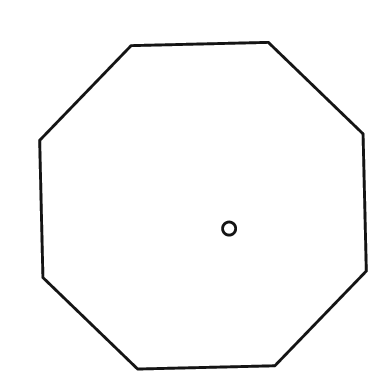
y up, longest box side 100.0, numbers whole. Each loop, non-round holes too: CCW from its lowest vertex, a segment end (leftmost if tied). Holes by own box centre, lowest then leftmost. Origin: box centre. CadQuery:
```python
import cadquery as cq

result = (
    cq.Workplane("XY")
    .moveTo(-20.0, -50.0)
    .lineTo(22.0, -49.0)
    .lineTo(50.0, -20.0)
    .lineTo(49.0, 22.0)
    .lineTo(20.0, 50.0)
    .lineTo(-22.0, 49.0)
    .lineTo(-50.0, 20.0)
    .lineTo(-49.0, -22.0)
    .close()
    .moveTo(8.0, -7.0)
    .circle(2.0)
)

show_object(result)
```